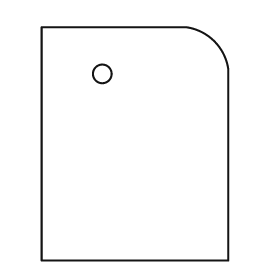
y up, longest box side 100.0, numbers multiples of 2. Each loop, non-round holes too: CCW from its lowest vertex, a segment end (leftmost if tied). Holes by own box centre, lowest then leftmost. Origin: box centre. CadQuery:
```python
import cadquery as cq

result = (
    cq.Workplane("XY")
    .moveTo(-40.0, -50.0)
    .lineTo(40.0, -50.0)
    .lineTo(40.0, 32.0)
    .threePointArc((34.0, 44.0), (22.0, 50.0))
    .lineTo(-40.0, 50.0)
    .close()
    .moveTo(-14.0, 30.0)
    .circle(4.0)
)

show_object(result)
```